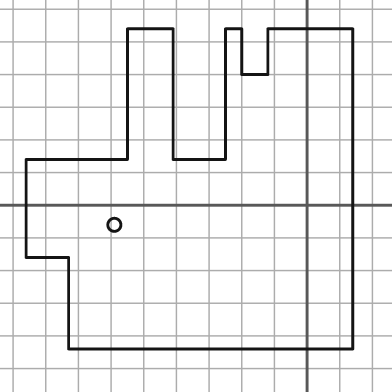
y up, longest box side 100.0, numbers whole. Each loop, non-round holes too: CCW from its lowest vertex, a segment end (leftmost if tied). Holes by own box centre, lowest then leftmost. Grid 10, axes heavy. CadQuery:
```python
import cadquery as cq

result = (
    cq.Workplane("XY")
    .moveTo(-73.0, -44.0)
    .lineTo(14.0, -44.0)
    .lineTo(14.0, 54.0)
    .lineTo(-12.0, 54.0)
    .lineTo(-12.0, 40.0)
    .lineTo(-20.0, 40.0)
    .lineTo(-20.0, 54.0)
    .lineTo(-25.0, 54.0)
    .lineTo(-25.0, 14.0)
    .lineTo(-41.0, 14.0)
    .lineTo(-41.0, 54.0)
    .lineTo(-55.0, 54.0)
    .lineTo(-55.0, 14.0)
    .lineTo(-86.0, 14.0)
    .lineTo(-86.0, -16.0)
    .lineTo(-73.0, -16.0)
    .close()
    .moveTo(-59.0, -6.0)
    .circle(2.0)
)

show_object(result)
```